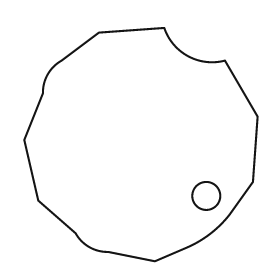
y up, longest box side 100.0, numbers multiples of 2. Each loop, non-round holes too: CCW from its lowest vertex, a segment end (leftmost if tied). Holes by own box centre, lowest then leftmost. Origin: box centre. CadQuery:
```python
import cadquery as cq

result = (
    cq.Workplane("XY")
    .moveTo(6.0, -50.0)
    .lineTo(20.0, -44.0)
    .threePointArc((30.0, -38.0), (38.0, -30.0))
    .lineTo(48.0, -16.0)
    .lineTo(50.0, 12.0)
    .lineTo(36.0, 36.0)
    .threePointArc((20.0, 38.0), (10.0, 50.0))
    .lineTo(-18.0, 48.0)
    .lineTo(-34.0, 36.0)
    .threePointArc((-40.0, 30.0), (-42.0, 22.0))
    .lineTo(-50.0, 2.0)
    .lineTo(-44.0, -24.0)
    .lineTo(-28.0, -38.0)
    .threePointArc((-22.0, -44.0), (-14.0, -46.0))
    .close()
    .moveTo(28.0, -22.0)
    .circle(6.0)
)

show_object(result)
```